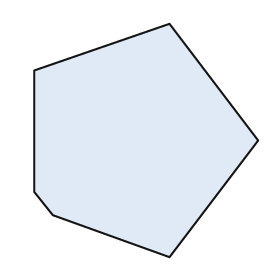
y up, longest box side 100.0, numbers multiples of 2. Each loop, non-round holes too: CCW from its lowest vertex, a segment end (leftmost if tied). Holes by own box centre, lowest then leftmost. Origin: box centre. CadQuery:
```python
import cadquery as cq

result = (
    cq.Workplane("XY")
    .moveTo(10.0, -50.0)
    .lineTo(48.0, 0.0)
    .lineTo(10.0, 50.0)
    .lineTo(-48.0, 30.0)
    .lineTo(-48.0, -22.0)
    .lineTo(-40.0, -32.0)
    .close()
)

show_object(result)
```